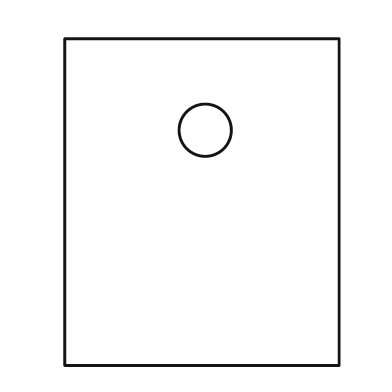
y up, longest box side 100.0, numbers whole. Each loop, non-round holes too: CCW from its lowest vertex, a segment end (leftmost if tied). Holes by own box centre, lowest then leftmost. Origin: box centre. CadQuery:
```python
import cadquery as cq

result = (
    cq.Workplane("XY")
    .moveTo(-42.0, -50.0)
    .lineTo(42.0, -50.0)
    .lineTo(42.0, 50.0)
    .lineTo(-42.0, 50.0)
    .close()
    .moveTo(1.0, 22.0)
    .circle(8.0)
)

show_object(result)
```